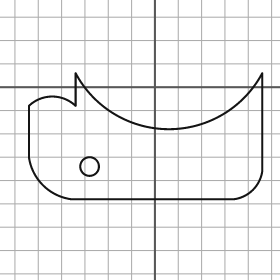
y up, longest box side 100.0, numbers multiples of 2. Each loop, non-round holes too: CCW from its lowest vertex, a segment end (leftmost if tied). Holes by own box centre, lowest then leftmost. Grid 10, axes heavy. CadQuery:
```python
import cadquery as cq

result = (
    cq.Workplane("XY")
    .moveTo(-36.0, -48.0)
    .lineTo(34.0, -48.0)
    .threePointArc((42.0, -44.0), (46.0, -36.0))
    .lineTo(46.0, 6.0)
    .threePointArc((6.0, -18.0), (-34.0, 6.0))
    .lineTo(-34.0, -8.0)
    .threePointArc((-44.0, -4.0), (-54.0, -8.0))
    .lineTo(-54.0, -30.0)
    .threePointArc((-48.0, -42.0), (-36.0, -48.0))
    .close()
    .moveTo(-28.0, -34.0)
    .circle(4.0)
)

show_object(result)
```